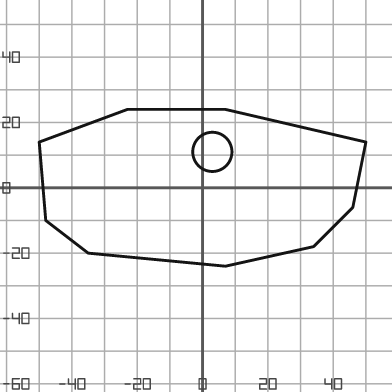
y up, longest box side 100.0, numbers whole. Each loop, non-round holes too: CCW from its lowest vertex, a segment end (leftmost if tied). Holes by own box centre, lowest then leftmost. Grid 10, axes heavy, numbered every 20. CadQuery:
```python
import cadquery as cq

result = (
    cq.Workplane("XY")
    .moveTo(7.0, -24.0)
    .lineTo(34.0, -18.0)
    .lineTo(46.0, -6.0)
    .lineTo(50.0, 14.0)
    .lineTo(7.0, 24.0)
    .lineTo(-23.0, 24.0)
    .lineTo(-50.0, 14.0)
    .lineTo(-48.0, -10.0)
    .lineTo(-35.0, -20.0)
    .close()
    .moveTo(3.0, 11.0)
    .circle(6.0)
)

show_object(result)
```